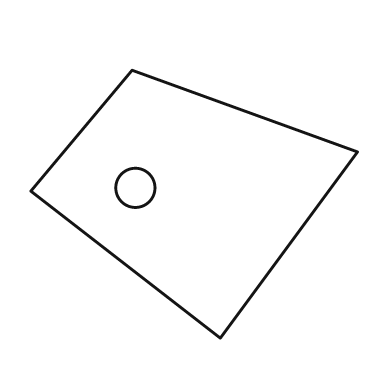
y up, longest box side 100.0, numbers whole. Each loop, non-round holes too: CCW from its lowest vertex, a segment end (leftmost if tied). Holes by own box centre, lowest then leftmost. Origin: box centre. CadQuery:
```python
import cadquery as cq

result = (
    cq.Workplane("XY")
    .moveTo(8.0, -41.0)
    .lineTo(50.0, 16.0)
    .lineTo(-19.0, 41.0)
    .lineTo(-50.0, 4.0)
    .close()
    .moveTo(-18.0, 5.0)
    .circle(6.0)
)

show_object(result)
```